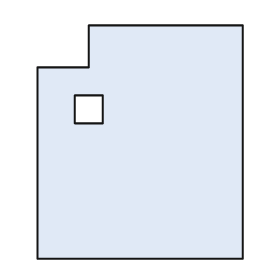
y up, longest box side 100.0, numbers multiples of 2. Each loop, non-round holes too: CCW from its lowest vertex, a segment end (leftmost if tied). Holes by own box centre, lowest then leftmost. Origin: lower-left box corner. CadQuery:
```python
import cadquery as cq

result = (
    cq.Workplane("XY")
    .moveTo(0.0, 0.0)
    .lineTo(88.0, 0.0)
    .lineTo(88.0, 100.0)
    .lineTo(22.0, 100.0)
    .lineTo(22.0, 82.0)
    .lineTo(0.0, 82.0)
    .close()
    .moveTo(16.0, 58.0)
    .lineTo(28.0, 58.0)
    .lineTo(28.0, 70.0)
    .lineTo(16.0, 70.0)
    .close()
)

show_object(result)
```